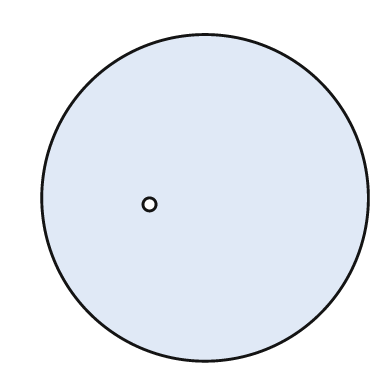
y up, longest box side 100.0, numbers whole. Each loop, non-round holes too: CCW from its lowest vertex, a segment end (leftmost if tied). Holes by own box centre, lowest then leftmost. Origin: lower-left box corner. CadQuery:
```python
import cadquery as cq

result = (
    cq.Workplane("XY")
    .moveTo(50.0, 50.0)
    .circle(50.0)
    .moveTo(33.0, 48.0)
    .circle(2.0)
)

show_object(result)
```